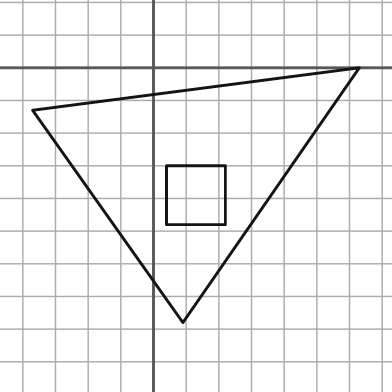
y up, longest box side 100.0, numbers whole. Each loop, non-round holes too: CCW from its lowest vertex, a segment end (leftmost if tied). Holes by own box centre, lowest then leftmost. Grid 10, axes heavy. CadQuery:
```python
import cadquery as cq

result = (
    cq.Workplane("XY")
    .moveTo(9.0, -78.0)
    .lineTo(63.0, 0.0)
    .lineTo(-37.0, -13.0)
    .close()
    .moveTo(4.0, -48.0)
    .lineTo(22.0, -48.0)
    .lineTo(22.0, -30.0)
    .lineTo(4.0, -30.0)
    .close()
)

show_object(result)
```